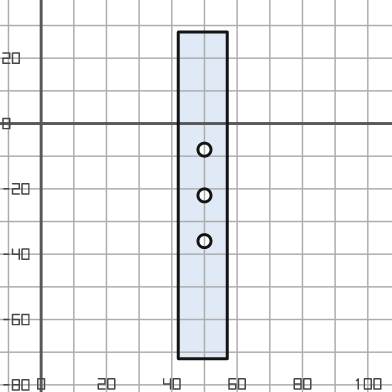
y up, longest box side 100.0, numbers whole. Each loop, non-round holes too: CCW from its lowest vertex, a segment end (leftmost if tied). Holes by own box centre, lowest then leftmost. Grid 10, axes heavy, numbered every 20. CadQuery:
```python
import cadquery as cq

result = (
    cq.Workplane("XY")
    .moveTo(42.0, -72.0)
    .lineTo(57.0, -72.0)
    .lineTo(57.0, 28.0)
    .lineTo(42.0, 28.0)
    .close()
    .moveTo(50.0, -36.0)
    .circle(2.0)
    .moveTo(50.0, -22.0)
    .circle(2.0)
    .moveTo(50.0, -8.0)
    .circle(2.0)
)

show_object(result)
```